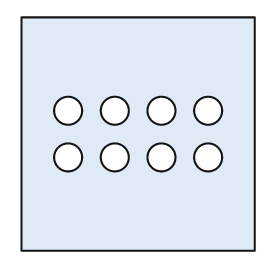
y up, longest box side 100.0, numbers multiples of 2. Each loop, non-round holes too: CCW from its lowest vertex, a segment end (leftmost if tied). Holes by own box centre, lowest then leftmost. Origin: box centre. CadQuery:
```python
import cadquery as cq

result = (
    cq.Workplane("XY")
    .moveTo(-50.0, -50.0)
    .lineTo(50.0, -50.0)
    .lineTo(50.0, 50.0)
    .lineTo(-50.0, 50.0)
    .close()
    .moveTo(-30.0, -10.0)
    .circle(6.0)
    .moveTo(-10.0, -10.0)
    .circle(6.0)
    .moveTo(10.0, -10.0)
    .circle(6.0)
    .moveTo(30.0, -10.0)
    .circle(6.0)
    .moveTo(-30.0, 10.0)
    .circle(6.0)
    .moveTo(-10.0, 10.0)
    .circle(6.0)
    .moveTo(10.0, 10.0)
    .circle(6.0)
    .moveTo(30.0, 10.0)
    .circle(6.0)
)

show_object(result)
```